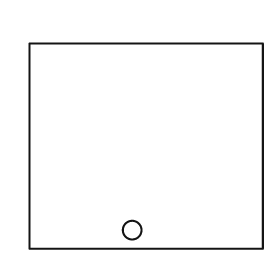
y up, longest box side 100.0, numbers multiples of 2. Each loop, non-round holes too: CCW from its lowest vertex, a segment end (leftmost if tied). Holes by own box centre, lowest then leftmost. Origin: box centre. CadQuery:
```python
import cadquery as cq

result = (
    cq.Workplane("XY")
    .moveTo(-50.0, -44.0)
    .lineTo(50.0, -44.0)
    .lineTo(50.0, 44.0)
    .lineTo(-50.0, 44.0)
    .close()
    .moveTo(-6.0, -36.0)
    .circle(4.0)
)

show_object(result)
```